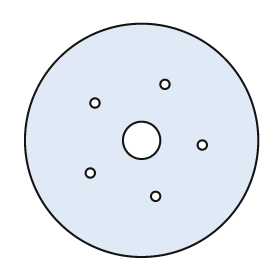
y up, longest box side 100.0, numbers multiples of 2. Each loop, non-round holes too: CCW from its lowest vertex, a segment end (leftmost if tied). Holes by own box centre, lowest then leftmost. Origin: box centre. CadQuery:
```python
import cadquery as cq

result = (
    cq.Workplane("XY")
    .moveTo(0.0, 0.0)
    .circle(50.0)
    .moveTo(6.0, -24.0)
    .circle(2.0)
    .moveTo(-22.0, -14.0)
    .circle(2.0)
    .moveTo(26.0, -2.0)
    .circle(2.0)
    .moveTo(0.0, 0.0)
    .circle(8.0)
    .moveTo(-20.0, 16.0)
    .circle(2.0)
    .moveTo(10.0, 24.0)
    .circle(2.0)
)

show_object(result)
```